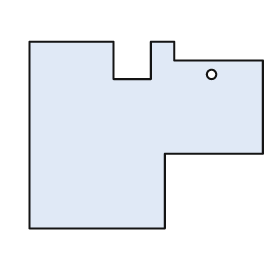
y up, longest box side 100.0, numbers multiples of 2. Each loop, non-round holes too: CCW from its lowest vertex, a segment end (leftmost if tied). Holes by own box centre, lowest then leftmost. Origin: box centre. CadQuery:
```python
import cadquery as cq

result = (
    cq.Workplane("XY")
    .moveTo(-50.0, -40.0)
    .lineTo(8.0, -40.0)
    .lineTo(8.0, -8.0)
    .lineTo(50.0, -8.0)
    .lineTo(50.0, 32.0)
    .lineTo(12.0, 32.0)
    .lineTo(12.0, 40.0)
    .lineTo(2.0, 40.0)
    .lineTo(2.0, 24.0)
    .lineTo(-14.0, 24.0)
    .lineTo(-14.0, 40.0)
    .lineTo(-50.0, 40.0)
    .close()
    .moveTo(28.0, 26.0)
    .circle(2.0)
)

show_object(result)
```